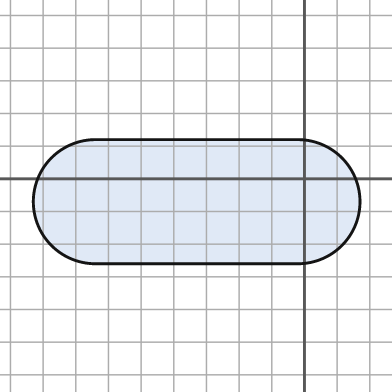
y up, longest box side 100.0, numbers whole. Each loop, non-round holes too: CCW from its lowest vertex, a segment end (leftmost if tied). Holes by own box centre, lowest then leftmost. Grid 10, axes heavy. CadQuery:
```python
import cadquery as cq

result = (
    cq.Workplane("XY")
    .moveTo(-64.0, -26.0)
    .lineTo(-2.0, -26.0)
    .threePointArc((17.0, -7.0), (-2.0, 12.0))
    .lineTo(-64.0, 12.0)
    .threePointArc((-83.0, -7.0), (-64.0, -26.0))
    .close()
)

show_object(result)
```